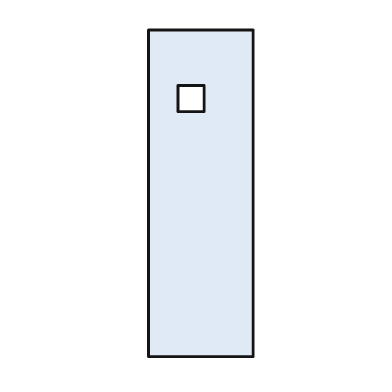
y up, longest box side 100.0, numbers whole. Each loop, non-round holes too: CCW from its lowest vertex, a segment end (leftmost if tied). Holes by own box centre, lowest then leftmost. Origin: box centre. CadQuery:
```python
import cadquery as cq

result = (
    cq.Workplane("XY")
    .moveTo(-16.0, -50.0)
    .lineTo(16.0, -50.0)
    .lineTo(16.0, 50.0)
    .lineTo(-16.0, 50.0)
    .close()
    .moveTo(-7.0, 25.0)
    .lineTo(1.0, 25.0)
    .lineTo(1.0, 33.0)
    .lineTo(-7.0, 33.0)
    .close()
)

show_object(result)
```